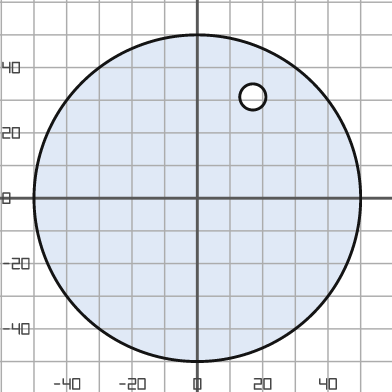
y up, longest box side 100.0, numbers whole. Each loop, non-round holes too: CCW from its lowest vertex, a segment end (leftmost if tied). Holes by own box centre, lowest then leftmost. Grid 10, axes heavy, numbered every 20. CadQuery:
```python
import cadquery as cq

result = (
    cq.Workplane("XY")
    .moveTo(0.0, 0.0)
    .circle(50.0)
    .moveTo(17.0, 31.0)
    .circle(4.0)
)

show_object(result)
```